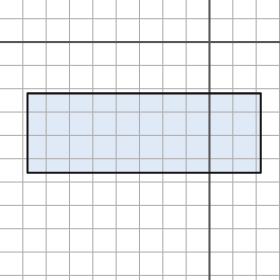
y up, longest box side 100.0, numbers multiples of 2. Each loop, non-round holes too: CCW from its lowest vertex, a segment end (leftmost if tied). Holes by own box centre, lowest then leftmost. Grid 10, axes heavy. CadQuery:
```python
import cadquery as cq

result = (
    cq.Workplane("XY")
    .moveTo(-78.0, -56.0)
    .lineTo(22.0, -56.0)
    .lineTo(22.0, -22.0)
    .lineTo(-78.0, -22.0)
    .close()
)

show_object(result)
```